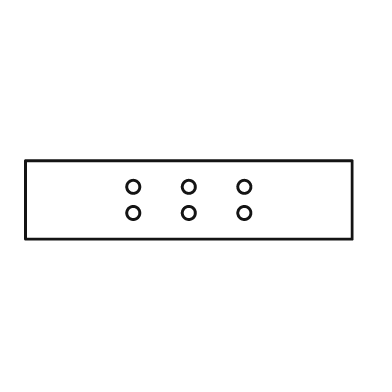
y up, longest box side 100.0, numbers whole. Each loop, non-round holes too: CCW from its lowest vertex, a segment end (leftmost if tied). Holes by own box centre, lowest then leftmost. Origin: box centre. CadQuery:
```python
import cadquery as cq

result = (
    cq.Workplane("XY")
    .moveTo(-50.0, -12.0)
    .lineTo(50.0, -12.0)
    .lineTo(50.0, 12.0)
    .lineTo(-50.0, 12.0)
    .close()
    .moveTo(-17.0, -4.0)
    .circle(2.0)
    .moveTo(0.0, -4.0)
    .circle(2.0)
    .moveTo(17.0, -4.0)
    .circle(2.0)
    .moveTo(-17.0, 4.0)
    .circle(2.0)
    .moveTo(0.0, 4.0)
    .circle(2.0)
    .moveTo(17.0, 4.0)
    .circle(2.0)
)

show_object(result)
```